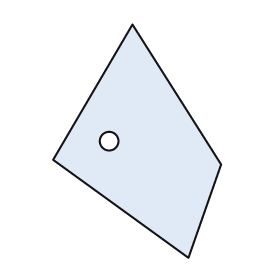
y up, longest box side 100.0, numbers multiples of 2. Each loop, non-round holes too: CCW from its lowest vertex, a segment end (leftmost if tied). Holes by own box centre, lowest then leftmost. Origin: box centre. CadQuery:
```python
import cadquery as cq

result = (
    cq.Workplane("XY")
    .moveTo(22.0, -50.0)
    .lineTo(36.0, -10.0)
    .lineTo(-2.0, 50.0)
    .lineTo(-36.0, -8.0)
    .close()
    .moveTo(-12.0, 0.0)
    .circle(4.0)
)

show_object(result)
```